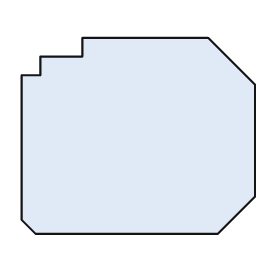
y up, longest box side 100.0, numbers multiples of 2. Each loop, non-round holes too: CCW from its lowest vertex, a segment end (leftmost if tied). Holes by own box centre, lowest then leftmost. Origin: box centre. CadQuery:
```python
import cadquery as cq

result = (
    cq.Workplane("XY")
    .moveTo(-44.0, -42.0)
    .lineTo(34.0, -42.0)
    .lineTo(50.0, -26.0)
    .lineTo(50.0, 22.0)
    .lineTo(30.0, 42.0)
    .lineTo(-24.0, 42.0)
    .lineTo(-24.0, 34.0)
    .lineTo(-42.0, 34.0)
    .lineTo(-42.0, 26.0)
    .lineTo(-50.0, 26.0)
    .lineTo(-50.0, -36.0)
    .close()
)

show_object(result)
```